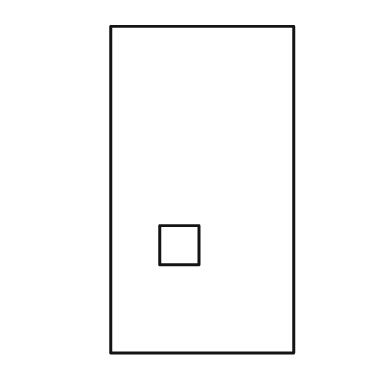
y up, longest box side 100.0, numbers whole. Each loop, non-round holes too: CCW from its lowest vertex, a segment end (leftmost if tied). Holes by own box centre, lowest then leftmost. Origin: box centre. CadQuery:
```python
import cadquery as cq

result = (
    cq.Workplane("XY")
    .moveTo(-28.0, -50.0)
    .lineTo(28.0, -50.0)
    .lineTo(28.0, 50.0)
    .lineTo(-28.0, 50.0)
    .close()
    .moveTo(-13.0, -23.0)
    .lineTo(-1.0, -23.0)
    .lineTo(-1.0, -11.0)
    .lineTo(-13.0, -11.0)
    .close()
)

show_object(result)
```